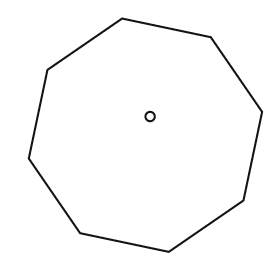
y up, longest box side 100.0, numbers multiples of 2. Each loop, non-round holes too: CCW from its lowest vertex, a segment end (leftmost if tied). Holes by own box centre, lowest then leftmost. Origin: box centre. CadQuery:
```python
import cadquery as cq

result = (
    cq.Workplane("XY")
    .moveTo(10.0, -50.0)
    .lineTo(42.0, -28.0)
    .lineTo(50.0, 10.0)
    .lineTo(28.0, 42.0)
    .lineTo(-10.0, 50.0)
    .lineTo(-42.0, 28.0)
    .lineTo(-50.0, -10.0)
    .lineTo(-28.0, -42.0)
    .close()
    .moveTo(2.0, 8.0)
    .circle(2.0)
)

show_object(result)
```